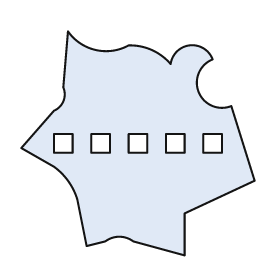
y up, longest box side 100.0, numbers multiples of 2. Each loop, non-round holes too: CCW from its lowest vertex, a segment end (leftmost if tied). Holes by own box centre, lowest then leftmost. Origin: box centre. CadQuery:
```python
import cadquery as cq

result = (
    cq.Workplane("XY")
    .moveTo(20.0, -48.0)
    .lineTo(20.0, -30.0)
    .lineTo(50.0, -16.0)
    .lineTo(40.0, 16.0)
    .threePointArc((26.0, 22.0), (32.0, 36.0))
    .threePointArc((22.0, 42.0), (14.0, 34.0))
    .threePointArc((6.0, 40.0), (-4.0, 42.0))
    .threePointArc((-18.0, 40.0), (-30.0, 48.0))
    .lineTo(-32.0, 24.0)
    .threePointArc((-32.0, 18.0), (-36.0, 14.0))
    .lineTo(-50.0, -2.0)
    .lineTo(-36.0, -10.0)
    .threePointArc((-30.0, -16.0), (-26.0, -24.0))
    .lineTo(-22.0, -44.0)
    .lineTo(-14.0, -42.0)
    .threePointArc((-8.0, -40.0), (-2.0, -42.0))
    .close()
    .moveTo(-36.0, -4.0)
    .lineTo(-28.0, -4.0)
    .lineTo(-28.0, 4.0)
    .lineTo(-36.0, 4.0)
    .close()
    .moveTo(-20.0, -4.0)
    .lineTo(-12.0, -4.0)
    .lineTo(-12.0, 4.0)
    .lineTo(-20.0, 4.0)
    .close()
    .moveTo(-4.0, -4.0)
    .lineTo(4.0, -4.0)
    .lineTo(4.0, 4.0)
    .lineTo(-4.0, 4.0)
    .close()
    .moveTo(12.0, -4.0)
    .lineTo(20.0, -4.0)
    .lineTo(20.0, 4.0)
    .lineTo(12.0, 4.0)
    .close()
    .moveTo(28.0, -4.0)
    .lineTo(36.0, -4.0)
    .lineTo(36.0, 4.0)
    .lineTo(28.0, 4.0)
    .close()
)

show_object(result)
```